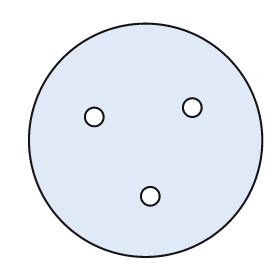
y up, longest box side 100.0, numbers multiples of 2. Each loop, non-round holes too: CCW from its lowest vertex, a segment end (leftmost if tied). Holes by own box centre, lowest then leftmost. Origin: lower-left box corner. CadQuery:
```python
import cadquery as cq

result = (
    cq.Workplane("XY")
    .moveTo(50.0, 50.0)
    .circle(50.0)
    .moveTo(52.0, 26.0)
    .circle(4.0)
    .moveTo(28.0, 60.0)
    .circle(4.0)
    .moveTo(70.0, 64.0)
    .circle(4.0)
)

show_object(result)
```